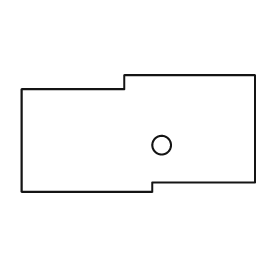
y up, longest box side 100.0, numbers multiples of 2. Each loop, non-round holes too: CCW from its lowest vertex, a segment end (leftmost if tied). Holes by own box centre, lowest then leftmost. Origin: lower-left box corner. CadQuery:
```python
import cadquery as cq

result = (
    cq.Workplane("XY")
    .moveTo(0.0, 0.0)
    .lineTo(56.0, 0.0)
    .lineTo(56.0, 4.0)
    .lineTo(100.0, 4.0)
    .lineTo(100.0, 50.0)
    .lineTo(44.0, 50.0)
    .lineTo(44.0, 44.0)
    .lineTo(0.0, 44.0)
    .close()
    .moveTo(60.0, 20.0)
    .circle(4.0)
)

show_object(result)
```